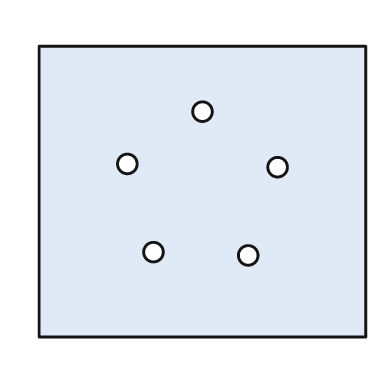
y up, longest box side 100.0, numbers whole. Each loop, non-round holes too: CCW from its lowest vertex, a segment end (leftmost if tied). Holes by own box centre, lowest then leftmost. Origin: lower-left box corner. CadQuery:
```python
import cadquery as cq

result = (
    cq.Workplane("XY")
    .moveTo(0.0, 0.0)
    .lineTo(100.0, 0.0)
    .lineTo(100.0, 89.0)
    .lineTo(0.0, 89.0)
    .close()
    .moveTo(64.0, 25.0)
    .circle(3.0)
    .moveTo(35.0, 26.0)
    .circle(3.0)
    .moveTo(73.0, 52.0)
    .circle(3.0)
    .moveTo(27.0, 53.0)
    .circle(3.0)
    .moveTo(50.0, 69.0)
    .circle(3.0)
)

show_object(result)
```